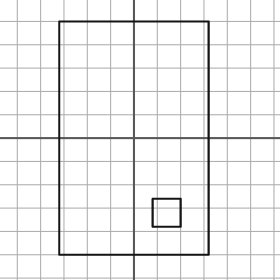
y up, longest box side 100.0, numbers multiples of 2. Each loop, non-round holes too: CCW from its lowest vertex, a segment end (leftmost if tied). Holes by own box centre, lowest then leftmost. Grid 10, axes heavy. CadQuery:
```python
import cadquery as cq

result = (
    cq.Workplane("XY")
    .moveTo(-32.0, -50.0)
    .lineTo(32.0, -50.0)
    .lineTo(32.0, 50.0)
    .lineTo(-32.0, 50.0)
    .close()
    .moveTo(8.0, -38.0)
    .lineTo(20.0, -38.0)
    .lineTo(20.0, -26.0)
    .lineTo(8.0, -26.0)
    .close()
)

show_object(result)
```